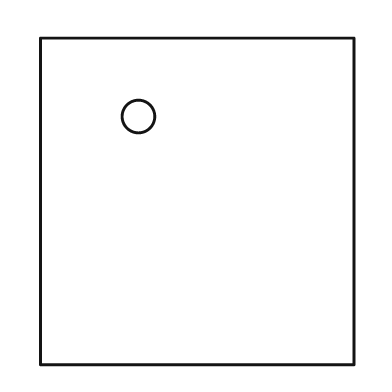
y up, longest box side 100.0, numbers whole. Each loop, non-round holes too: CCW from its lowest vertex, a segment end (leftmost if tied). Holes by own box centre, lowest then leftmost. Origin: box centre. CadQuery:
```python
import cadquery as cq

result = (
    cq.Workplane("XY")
    .moveTo(-48.0, -50.0)
    .lineTo(48.0, -50.0)
    .lineTo(48.0, 50.0)
    .lineTo(-48.0, 50.0)
    .close()
    .moveTo(-18.0, 26.0)
    .circle(5.0)
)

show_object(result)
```